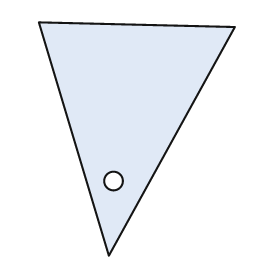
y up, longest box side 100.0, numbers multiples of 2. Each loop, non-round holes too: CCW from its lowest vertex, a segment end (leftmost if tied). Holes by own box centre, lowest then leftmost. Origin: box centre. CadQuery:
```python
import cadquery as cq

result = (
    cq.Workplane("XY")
    .moveTo(-12.0, -50.0)
    .lineTo(42.0, 48.0)
    .lineTo(-42.0, 50.0)
    .close()
    .moveTo(-10.0, -18.0)
    .circle(4.0)
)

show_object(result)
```